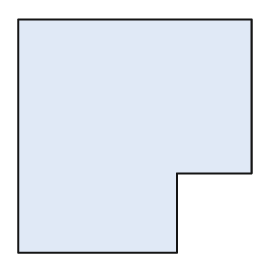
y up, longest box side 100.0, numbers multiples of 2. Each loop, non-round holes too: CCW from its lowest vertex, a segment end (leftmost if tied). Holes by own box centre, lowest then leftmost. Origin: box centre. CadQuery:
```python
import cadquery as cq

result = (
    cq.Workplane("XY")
    .moveTo(-50.0, -50.0)
    .lineTo(18.0, -50.0)
    .lineTo(18.0, -16.0)
    .lineTo(50.0, -16.0)
    .lineTo(50.0, 50.0)
    .lineTo(-50.0, 50.0)
    .close()
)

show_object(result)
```